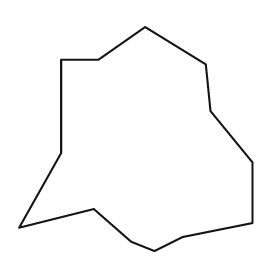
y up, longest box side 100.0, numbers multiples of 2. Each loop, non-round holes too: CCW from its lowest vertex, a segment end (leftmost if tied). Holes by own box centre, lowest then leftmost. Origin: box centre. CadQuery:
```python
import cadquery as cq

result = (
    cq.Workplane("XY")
    .moveTo(8.0, -48.0)
    .lineTo(20.0, -42.0)
    .lineTo(50.0, -36.0)
    .lineTo(50.0, -10.0)
    .lineTo(32.0, 12.0)
    .lineTo(30.0, 32.0)
    .lineTo(4.0, 48.0)
    .lineTo(-16.0, 34.0)
    .lineTo(-32.0, 34.0)
    .lineTo(-32.0, -6.0)
    .lineTo(-50.0, -38.0)
    .lineTo(-18.0, -30.0)
    .lineTo(-2.0, -44.0)
    .close()
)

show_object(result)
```